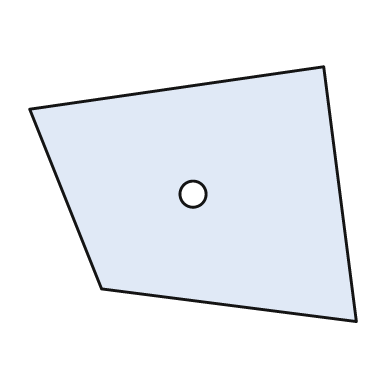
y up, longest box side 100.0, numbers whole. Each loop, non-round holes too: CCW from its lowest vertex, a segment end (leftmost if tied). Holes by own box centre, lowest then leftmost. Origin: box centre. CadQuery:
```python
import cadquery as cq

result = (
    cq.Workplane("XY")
    .moveTo(50.0, -39.0)
    .lineTo(40.0, 39.0)
    .lineTo(-50.0, 26.0)
    .lineTo(-28.0, -29.0)
    .close()
    .moveTo(0.0, 0.0)
    .circle(4.0)
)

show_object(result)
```